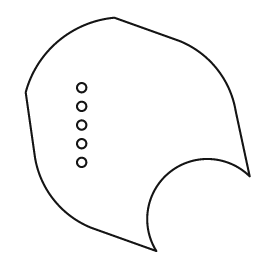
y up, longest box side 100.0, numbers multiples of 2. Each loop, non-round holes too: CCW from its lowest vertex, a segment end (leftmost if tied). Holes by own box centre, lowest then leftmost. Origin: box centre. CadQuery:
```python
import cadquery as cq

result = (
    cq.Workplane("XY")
    .moveTo(8.0, -50.0)
    .threePointArc((14.0, -16.0), (48.0, -18.0))
    .lineTo(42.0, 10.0)
    .threePointArc((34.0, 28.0), (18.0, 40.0))
    .lineTo(-10.0, 50.0)
    .threePointArc((-34.0, 40.0), (-48.0, 18.0))
    .lineTo(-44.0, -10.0)
    .threePointArc((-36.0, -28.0), (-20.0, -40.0))
    .close()
    .moveTo(-24.0, -12.0)
    .circle(2.0)
    .moveTo(-24.0, -4.0)
    .circle(2.0)
    .moveTo(-24.0, 4.0)
    .circle(2.0)
    .moveTo(-24.0, 12.0)
    .circle(2.0)
    .moveTo(-24.0, 20.0)
    .circle(2.0)
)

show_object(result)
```